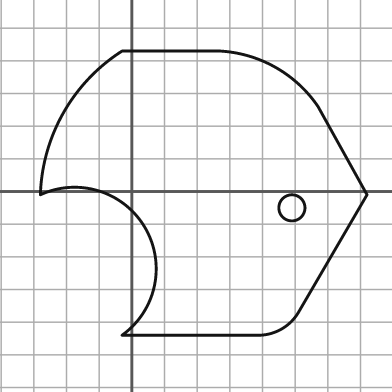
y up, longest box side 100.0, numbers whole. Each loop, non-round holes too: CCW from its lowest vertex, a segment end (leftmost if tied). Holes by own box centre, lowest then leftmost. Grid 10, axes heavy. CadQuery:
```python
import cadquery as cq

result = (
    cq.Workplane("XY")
    .moveTo(-3.0, -44.0)
    .lineTo(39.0, -44.0)
    .threePointArc((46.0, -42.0), (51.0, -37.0))
    .lineTo(72.0, -1.0)
    .lineTo(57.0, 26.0)
    .threePointArc((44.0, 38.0), (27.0, 43.0))
    .lineTo(-3.0, 43.0)
    .threePointArc((-21.0, 24.0), (-28.0, -1.0))
    .threePointArc((4.0, -11.0), (-3.0, -44.0))
    .close()
    .moveTo(49.0, -5.0)
    .circle(4.0)
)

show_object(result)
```